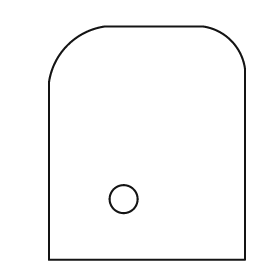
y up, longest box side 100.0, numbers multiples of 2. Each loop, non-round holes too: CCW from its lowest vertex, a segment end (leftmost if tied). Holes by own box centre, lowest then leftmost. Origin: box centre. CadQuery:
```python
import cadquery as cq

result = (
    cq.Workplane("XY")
    .moveTo(-42.0, -50.0)
    .lineTo(42.0, -50.0)
    .lineTo(42.0, 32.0)
    .threePointArc((36.0, 44.0), (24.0, 50.0))
    .lineTo(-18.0, 50.0)
    .threePointArc((-34.0, 42.0), (-42.0, 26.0))
    .close()
    .moveTo(-10.0, -24.0)
    .circle(6.0)
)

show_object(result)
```